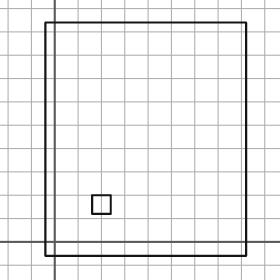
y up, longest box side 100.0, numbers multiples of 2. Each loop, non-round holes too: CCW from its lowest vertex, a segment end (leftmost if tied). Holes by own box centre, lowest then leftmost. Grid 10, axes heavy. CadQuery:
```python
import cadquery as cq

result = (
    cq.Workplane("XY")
    .moveTo(-4.0, -6.0)
    .lineTo(82.0, -6.0)
    .lineTo(82.0, 94.0)
    .lineTo(-4.0, 94.0)
    .close()
    .moveTo(16.0, 12.0)
    .lineTo(24.0, 12.0)
    .lineTo(24.0, 20.0)
    .lineTo(16.0, 20.0)
    .close()
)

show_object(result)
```